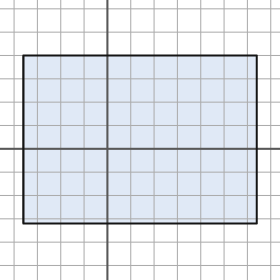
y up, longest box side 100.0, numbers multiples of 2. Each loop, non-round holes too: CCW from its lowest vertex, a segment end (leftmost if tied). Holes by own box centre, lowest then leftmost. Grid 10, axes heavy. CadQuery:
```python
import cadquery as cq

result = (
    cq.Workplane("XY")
    .moveTo(-36.0, -32.0)
    .lineTo(64.0, -32.0)
    .lineTo(64.0, 40.0)
    .lineTo(-36.0, 40.0)
    .close()
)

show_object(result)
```